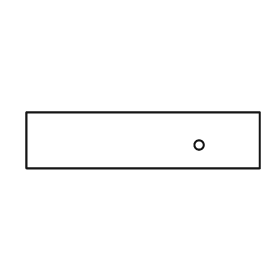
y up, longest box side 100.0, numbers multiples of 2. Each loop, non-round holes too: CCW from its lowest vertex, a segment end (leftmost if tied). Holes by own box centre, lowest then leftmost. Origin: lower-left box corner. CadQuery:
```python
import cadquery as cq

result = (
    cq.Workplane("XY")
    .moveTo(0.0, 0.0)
    .lineTo(100.0, 0.0)
    .lineTo(100.0, 24.0)
    .lineTo(0.0, 24.0)
    .close()
    .moveTo(74.0, 10.0)
    .circle(2.0)
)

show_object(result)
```